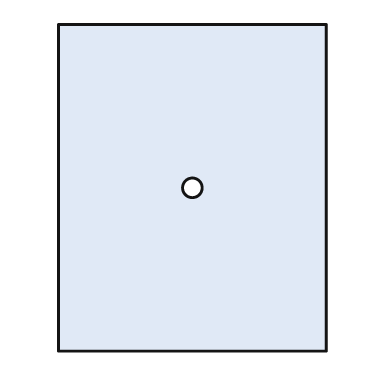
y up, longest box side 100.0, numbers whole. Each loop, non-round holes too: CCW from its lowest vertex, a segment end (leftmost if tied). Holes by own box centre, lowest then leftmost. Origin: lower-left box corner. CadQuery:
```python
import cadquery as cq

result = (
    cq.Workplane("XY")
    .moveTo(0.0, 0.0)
    .lineTo(82.0, 0.0)
    .lineTo(82.0, 100.0)
    .lineTo(0.0, 100.0)
    .close()
    .moveTo(41.0, 50.0)
    .circle(3.0)
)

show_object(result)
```